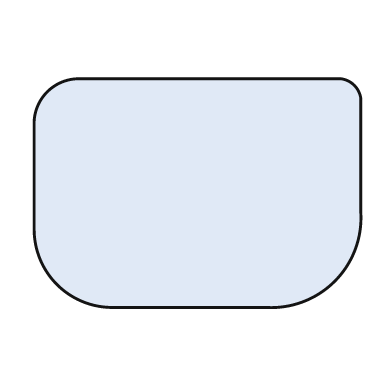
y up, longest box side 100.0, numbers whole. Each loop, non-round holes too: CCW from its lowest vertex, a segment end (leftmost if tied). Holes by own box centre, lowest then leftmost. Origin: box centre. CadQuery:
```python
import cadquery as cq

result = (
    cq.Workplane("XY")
    .moveTo(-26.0, -35.0)
    .lineTo(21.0, -35.0)
    .threePointArc((42.0, -27.0), (50.0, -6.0))
    .lineTo(50.0, 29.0)
    .threePointArc((48.0, 33.0), (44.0, 35.0))
    .lineTo(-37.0, 35.0)
    .threePointArc((-46.0, 31.0), (-50.0, 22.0))
    .lineTo(-50.0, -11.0)
    .threePointArc((-43.0, -28.0), (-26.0, -35.0))
    .close()
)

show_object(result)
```